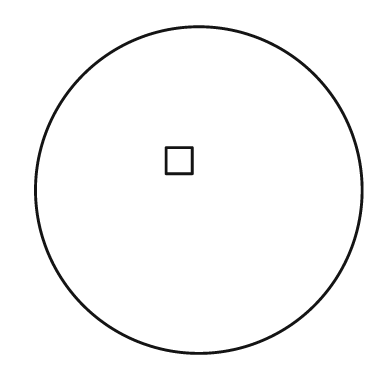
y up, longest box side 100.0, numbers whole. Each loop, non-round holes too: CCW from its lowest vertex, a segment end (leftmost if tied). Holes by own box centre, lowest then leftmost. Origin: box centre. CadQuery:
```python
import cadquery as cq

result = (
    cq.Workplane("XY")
    .moveTo(0.0, 0.0)
    .circle(50.0)
    .moveTo(-10.0, 5.0)
    .lineTo(-2.0, 5.0)
    .lineTo(-2.0, 13.0)
    .lineTo(-10.0, 13.0)
    .close()
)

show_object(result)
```